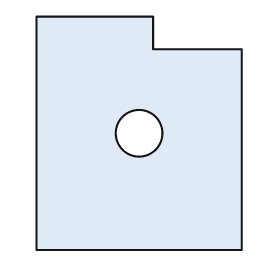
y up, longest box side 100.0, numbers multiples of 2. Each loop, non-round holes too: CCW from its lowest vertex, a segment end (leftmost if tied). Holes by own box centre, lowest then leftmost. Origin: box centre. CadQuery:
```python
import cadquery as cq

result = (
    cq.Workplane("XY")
    .moveTo(-44.0, -50.0)
    .lineTo(44.0, -50.0)
    .lineTo(44.0, 36.0)
    .lineTo(6.0, 36.0)
    .lineTo(6.0, 50.0)
    .lineTo(-44.0, 50.0)
    .close()
    .moveTo(0.0, 0.0)
    .circle(10.0)
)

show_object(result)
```